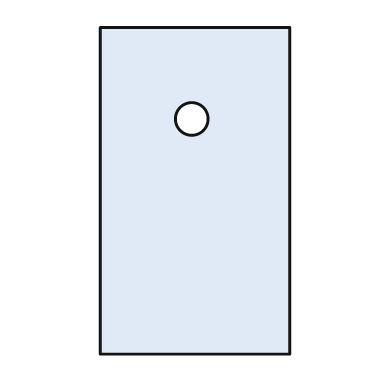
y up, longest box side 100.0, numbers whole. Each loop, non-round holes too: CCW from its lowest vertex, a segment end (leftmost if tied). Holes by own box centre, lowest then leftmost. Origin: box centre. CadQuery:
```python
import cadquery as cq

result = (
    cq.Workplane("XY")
    .moveTo(-29.0, -50.0)
    .lineTo(29.0, -50.0)
    .lineTo(29.0, 50.0)
    .lineTo(-29.0, 50.0)
    .close()
    .moveTo(-1.0, 22.0)
    .circle(5.0)
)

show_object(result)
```